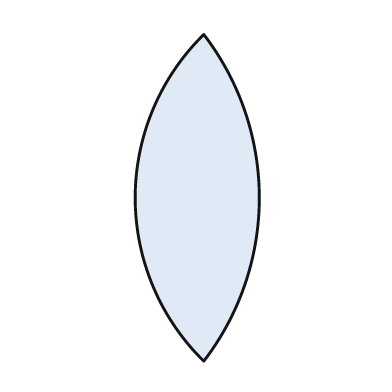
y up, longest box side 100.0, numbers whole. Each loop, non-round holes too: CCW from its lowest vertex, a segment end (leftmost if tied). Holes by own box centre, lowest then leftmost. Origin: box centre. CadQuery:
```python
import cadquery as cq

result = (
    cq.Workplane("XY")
    .moveTo(2.0, -50.0)
    .threePointArc((19.0, 0.0), (2.0, 50.0))
    .threePointArc((-19.0, 0.0), (2.0, -50.0))
    .close()
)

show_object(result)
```